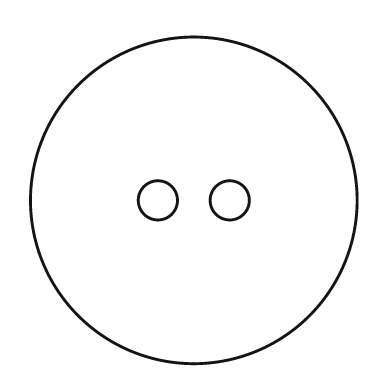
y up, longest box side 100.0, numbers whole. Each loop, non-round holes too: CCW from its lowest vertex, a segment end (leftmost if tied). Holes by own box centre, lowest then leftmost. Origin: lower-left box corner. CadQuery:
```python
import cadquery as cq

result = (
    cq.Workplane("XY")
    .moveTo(50.0, 50.0)
    .circle(50.0)
    .moveTo(39.0, 50.0)
    .circle(6.0)
    .moveTo(61.0, 50.0)
    .circle(6.0)
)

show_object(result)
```